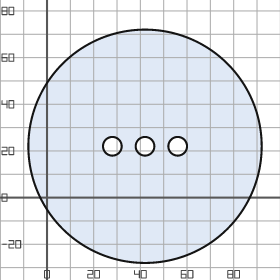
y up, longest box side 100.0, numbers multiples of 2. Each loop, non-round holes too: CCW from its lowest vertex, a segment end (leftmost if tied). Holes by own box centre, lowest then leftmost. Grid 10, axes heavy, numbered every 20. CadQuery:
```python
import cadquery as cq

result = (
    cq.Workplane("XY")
    .moveTo(42.0, 22.0)
    .circle(50.0)
    .moveTo(28.0, 22.0)
    .circle(4.0)
    .moveTo(42.0, 22.0)
    .circle(4.0)
    .moveTo(56.0, 22.0)
    .circle(4.0)
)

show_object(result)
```